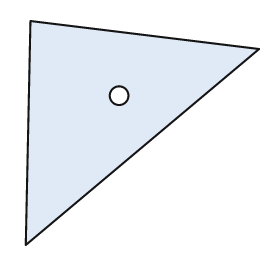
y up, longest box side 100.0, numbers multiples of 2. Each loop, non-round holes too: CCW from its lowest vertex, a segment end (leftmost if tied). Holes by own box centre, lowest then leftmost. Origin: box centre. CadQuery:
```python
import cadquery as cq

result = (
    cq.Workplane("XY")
    .moveTo(-50.0, -48.0)
    .lineTo(50.0, 36.0)
    .lineTo(-48.0, 48.0)
    .close()
    .moveTo(-10.0, 16.0)
    .circle(4.0)
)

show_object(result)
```